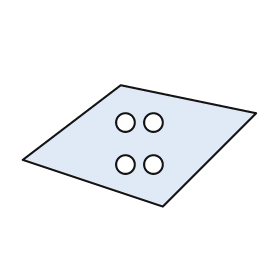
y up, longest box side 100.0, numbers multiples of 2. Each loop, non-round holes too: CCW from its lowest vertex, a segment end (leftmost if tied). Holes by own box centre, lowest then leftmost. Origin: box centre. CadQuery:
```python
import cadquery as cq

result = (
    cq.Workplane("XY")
    .moveTo(10.0, -26.0)
    .lineTo(50.0, 14.0)
    .lineTo(-8.0, 26.0)
    .lineTo(-50.0, -6.0)
    .close()
    .moveTo(-6.0, -8.0)
    .circle(4.0)
    .moveTo(6.0, -8.0)
    .circle(4.0)
    .moveTo(-6.0, 10.0)
    .circle(4.0)
    .moveTo(6.0, 10.0)
    .circle(4.0)
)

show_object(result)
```